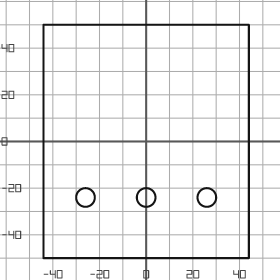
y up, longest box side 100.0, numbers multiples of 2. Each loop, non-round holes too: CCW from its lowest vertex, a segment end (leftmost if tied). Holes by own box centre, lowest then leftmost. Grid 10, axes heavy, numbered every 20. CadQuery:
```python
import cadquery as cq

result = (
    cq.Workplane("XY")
    .moveTo(-44.0, -50.0)
    .lineTo(44.0, -50.0)
    .lineTo(44.0, 50.0)
    .lineTo(-44.0, 50.0)
    .close()
    .moveTo(-26.0, -24.0)
    .circle(4.0)
    .moveTo(0.0, -24.0)
    .circle(4.0)
    .moveTo(26.0, -24.0)
    .circle(4.0)
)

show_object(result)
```